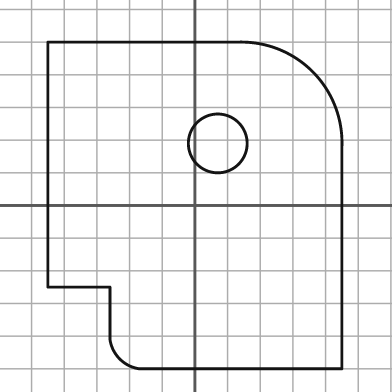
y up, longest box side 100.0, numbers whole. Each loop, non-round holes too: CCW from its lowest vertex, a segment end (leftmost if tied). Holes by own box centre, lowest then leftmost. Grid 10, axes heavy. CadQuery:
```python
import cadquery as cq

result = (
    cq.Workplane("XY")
    .moveTo(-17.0, -50.0)
    .lineTo(45.0, -50.0)
    .lineTo(45.0, 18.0)
    .threePointArc((36.0, 41.0), (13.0, 50.0))
    .lineTo(-45.0, 50.0)
    .lineTo(-45.0, -25.0)
    .lineTo(-26.0, -25.0)
    .lineTo(-26.0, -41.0)
    .threePointArc((-23.0, -47.0), (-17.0, -50.0))
    .close()
    .moveTo(7.0, 19.0)
    .circle(9.0)
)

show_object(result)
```